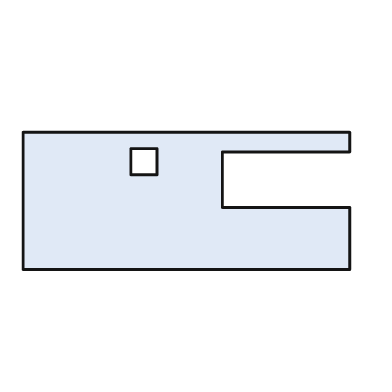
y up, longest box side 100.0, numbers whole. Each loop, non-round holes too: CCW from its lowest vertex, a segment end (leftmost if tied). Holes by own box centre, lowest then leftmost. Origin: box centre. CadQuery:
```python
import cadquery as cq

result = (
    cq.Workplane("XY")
    .moveTo(-50.0, -21.0)
    .lineTo(50.0, -21.0)
    .lineTo(50.0, -2.0)
    .lineTo(11.0, -2.0)
    .lineTo(11.0, 15.0)
    .lineTo(50.0, 15.0)
    .lineTo(50.0, 21.0)
    .lineTo(-50.0, 21.0)
    .close()
    .moveTo(-17.0, 8.0)
    .lineTo(-9.0, 8.0)
    .lineTo(-9.0, 16.0)
    .lineTo(-17.0, 16.0)
    .close()
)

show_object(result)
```